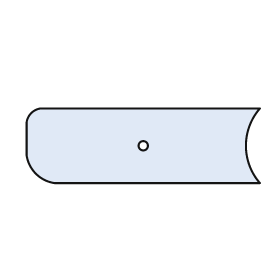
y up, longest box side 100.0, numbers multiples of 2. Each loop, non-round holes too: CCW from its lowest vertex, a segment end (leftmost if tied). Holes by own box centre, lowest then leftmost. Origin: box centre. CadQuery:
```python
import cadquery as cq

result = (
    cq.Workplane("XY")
    .moveTo(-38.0, -16.0)
    .lineTo(50.0, -16.0)
    .threePointArc((44.0, 0.0), (50.0, 16.0))
    .lineTo(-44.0, 16.0)
    .threePointArc((-48.0, 14.0), (-50.0, 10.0))
    .lineTo(-50.0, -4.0)
    .threePointArc((-46.0, -12.0), (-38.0, -16.0))
    .close()
    .moveTo(0.0, 0.0)
    .circle(2.0)
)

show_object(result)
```